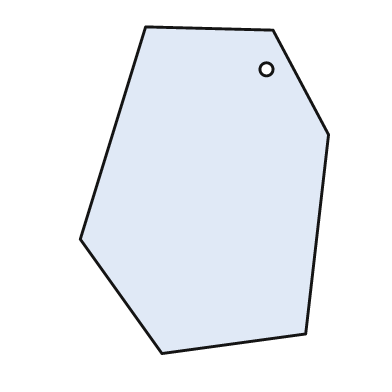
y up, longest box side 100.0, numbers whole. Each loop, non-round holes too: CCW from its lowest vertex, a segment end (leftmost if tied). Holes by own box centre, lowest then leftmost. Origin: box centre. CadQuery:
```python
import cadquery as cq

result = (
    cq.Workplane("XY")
    .moveTo(-13.0, -50.0)
    .lineTo(31.0, -44.0)
    .lineTo(38.0, 17.0)
    .lineTo(21.0, 49.0)
    .lineTo(-18.0, 50.0)
    .lineTo(-38.0, -15.0)
    .close()
    .moveTo(19.0, 37.0)
    .circle(2.0)
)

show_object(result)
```